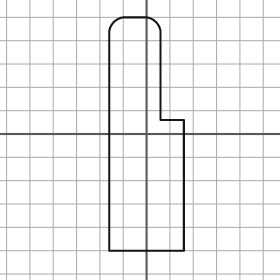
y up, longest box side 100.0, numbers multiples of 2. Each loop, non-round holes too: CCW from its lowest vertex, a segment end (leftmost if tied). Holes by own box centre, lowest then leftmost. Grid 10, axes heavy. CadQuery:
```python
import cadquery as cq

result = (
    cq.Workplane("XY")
    .moveTo(-16.0, -50.0)
    .lineTo(16.0, -50.0)
    .lineTo(16.0, 6.0)
    .lineTo(6.0, 6.0)
    .lineTo(6.0, 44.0)
    .threePointArc((4.0, 48.0), (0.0, 50.0))
    .lineTo(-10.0, 50.0)
    .threePointArc((-14.0, 48.0), (-16.0, 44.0))
    .close()
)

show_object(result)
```